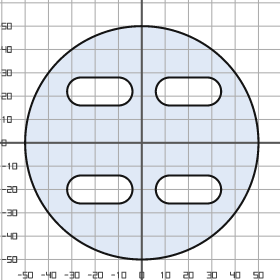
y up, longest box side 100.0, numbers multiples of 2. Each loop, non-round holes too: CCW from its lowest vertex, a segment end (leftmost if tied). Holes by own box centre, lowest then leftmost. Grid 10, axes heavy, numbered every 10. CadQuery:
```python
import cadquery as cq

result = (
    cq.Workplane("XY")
    .moveTo(0.0, 0.0)
    .circle(50.0)
    .moveTo(-26.0, -26.0)
    .lineTo(-10.0, -26.0)
    .threePointArc((-4.0, -20.0), (-10.0, -14.0))
    .lineTo(-26.0, -14.0)
    .threePointArc((-32.0, -20.0), (-26.0, -26.0))
    .close()
    .moveTo(12.0, -26.0)
    .lineTo(28.0, -26.0)
    .threePointArc((34.0, -20.0), (28.0, -14.0))
    .lineTo(12.0, -14.0)
    .threePointArc((6.0, -20.0), (12.0, -26.0))
    .close()
    .moveTo(-26.0, 16.0)
    .lineTo(-10.0, 16.0)
    .threePointArc((-4.0, 22.0), (-10.0, 28.0))
    .lineTo(-26.0, 28.0)
    .threePointArc((-32.0, 22.0), (-26.0, 16.0))
    .close()
    .moveTo(12.0, 16.0)
    .lineTo(28.0, 16.0)
    .threePointArc((34.0, 22.0), (28.0, 28.0))
    .lineTo(12.0, 28.0)
    .threePointArc((6.0, 22.0), (12.0, 16.0))
    .close()
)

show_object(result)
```